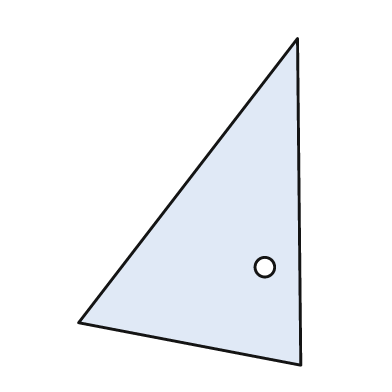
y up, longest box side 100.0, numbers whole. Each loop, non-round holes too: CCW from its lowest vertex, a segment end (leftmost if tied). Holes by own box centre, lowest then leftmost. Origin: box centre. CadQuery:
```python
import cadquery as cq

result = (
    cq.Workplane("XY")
    .moveTo(34.0, -50.0)
    .lineTo(33.0, 50.0)
    .lineTo(-34.0, -37.0)
    .close()
    .moveTo(23.0, -20.0)
    .circle(3.0)
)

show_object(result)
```